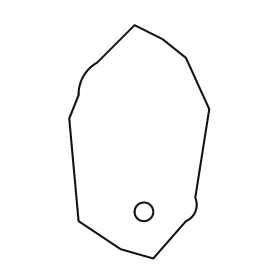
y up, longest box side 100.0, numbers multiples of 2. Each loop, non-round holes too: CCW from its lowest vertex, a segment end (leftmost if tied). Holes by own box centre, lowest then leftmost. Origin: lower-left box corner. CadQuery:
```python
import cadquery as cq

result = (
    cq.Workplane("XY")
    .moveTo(36.0, 0.0)
    .lineTo(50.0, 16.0)
    .threePointArc((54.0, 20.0), (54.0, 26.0))
    .lineTo(60.0, 64.0)
    .lineTo(50.0, 86.0)
    .lineTo(40.0, 94.0)
    .lineTo(28.0, 100.0)
    .lineTo(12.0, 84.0)
    .threePointArc((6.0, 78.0), (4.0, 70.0))
    .lineTo(0.0, 60.0)
    .lineTo(4.0, 16.0)
    .lineTo(22.0, 4.0)
    .close()
    .moveTo(32.0, 20.0)
    .circle(4.0)
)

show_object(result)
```